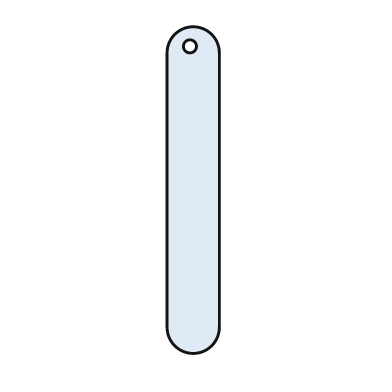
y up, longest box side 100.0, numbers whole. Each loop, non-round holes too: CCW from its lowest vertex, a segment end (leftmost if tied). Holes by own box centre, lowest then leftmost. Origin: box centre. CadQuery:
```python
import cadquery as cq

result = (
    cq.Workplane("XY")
    .moveTo(-8.0, -42.0)
    .threePointArc((0.0, -50.0), (8.0, -42.0))
    .lineTo(8.0, 42.0)
    .threePointArc((0.0, 50.0), (-8.0, 42.0))
    .close()
    .moveTo(-1.0, 44.0)
    .circle(2.0)
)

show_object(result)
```